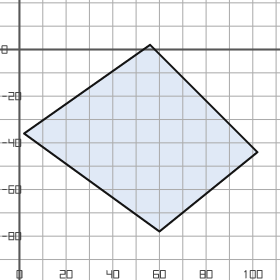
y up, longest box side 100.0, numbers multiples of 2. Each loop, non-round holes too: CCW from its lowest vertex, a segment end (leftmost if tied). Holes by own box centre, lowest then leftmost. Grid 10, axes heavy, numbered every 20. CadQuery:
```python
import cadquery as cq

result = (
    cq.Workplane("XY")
    .moveTo(60.0, -78.0)
    .lineTo(102.0, -44.0)
    .lineTo(56.0, 2.0)
    .lineTo(2.0, -36.0)
    .close()
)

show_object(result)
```